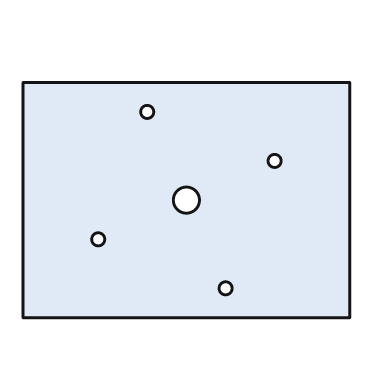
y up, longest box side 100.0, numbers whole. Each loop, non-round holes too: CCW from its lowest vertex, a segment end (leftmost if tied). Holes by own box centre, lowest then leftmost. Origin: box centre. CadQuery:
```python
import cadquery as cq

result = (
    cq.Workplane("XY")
    .moveTo(-50.0, -36.0)
    .lineTo(50.0, -36.0)
    .lineTo(50.0, 36.0)
    .lineTo(-50.0, 36.0)
    .close()
    .moveTo(12.0, -27.0)
    .circle(2.0)
    .moveTo(-27.0, -12.0)
    .circle(2.0)
    .moveTo(0.0, 0.0)
    .circle(4.0)
    .moveTo(27.0, 12.0)
    .circle(2.0)
    .moveTo(-12.0, 27.0)
    .circle(2.0)
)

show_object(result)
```